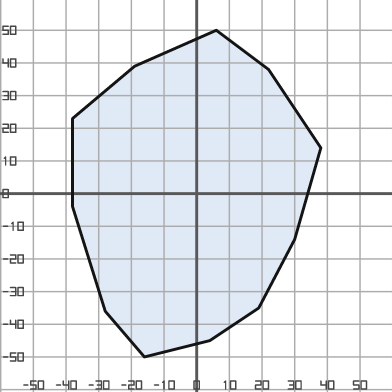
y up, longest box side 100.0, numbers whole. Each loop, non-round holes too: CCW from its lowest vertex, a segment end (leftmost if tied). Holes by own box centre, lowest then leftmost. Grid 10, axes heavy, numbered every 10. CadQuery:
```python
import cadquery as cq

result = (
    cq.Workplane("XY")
    .moveTo(-16.0, -50.0)
    .lineTo(4.0, -45.0)
    .lineTo(19.0, -35.0)
    .lineTo(30.0, -14.0)
    .lineTo(38.0, 14.0)
    .lineTo(22.0, 38.0)
    .lineTo(6.0, 50.0)
    .lineTo(-19.0, 39.0)
    .lineTo(-38.0, 23.0)
    .lineTo(-38.0, -4.0)
    .lineTo(-28.0, -36.0)
    .close()
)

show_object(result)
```